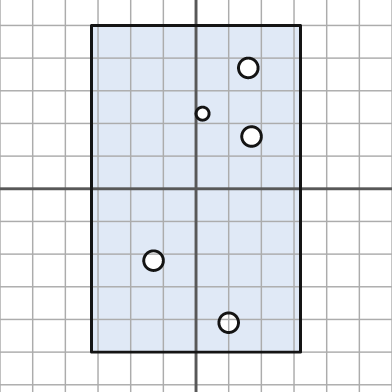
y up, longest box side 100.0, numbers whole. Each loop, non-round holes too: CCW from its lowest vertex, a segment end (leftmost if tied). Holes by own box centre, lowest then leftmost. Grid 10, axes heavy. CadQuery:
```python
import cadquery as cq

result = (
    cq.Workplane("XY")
    .moveTo(-32.0, -50.0)
    .lineTo(32.0, -50.0)
    .lineTo(32.0, 50.0)
    .lineTo(-32.0, 50.0)
    .close()
    .moveTo(10.0, -41.0)
    .circle(3.0)
    .moveTo(-13.0, -22.0)
    .circle(3.0)
    .moveTo(17.0, 16.0)
    .circle(3.0)
    .moveTo(2.0, 23.0)
    .circle(2.0)
    .moveTo(16.0, 37.0)
    .circle(3.0)
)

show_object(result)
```